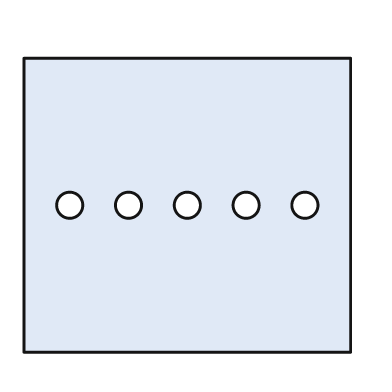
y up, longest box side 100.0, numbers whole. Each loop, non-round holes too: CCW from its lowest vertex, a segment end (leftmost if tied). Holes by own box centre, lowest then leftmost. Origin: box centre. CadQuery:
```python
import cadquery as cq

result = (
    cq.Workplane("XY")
    .moveTo(-50.0, -45.0)
    .lineTo(50.0, -45.0)
    .lineTo(50.0, 45.0)
    .lineTo(-50.0, 45.0)
    .close()
    .moveTo(-36.0, 0.0)
    .circle(4.0)
    .moveTo(-18.0, 0.0)
    .circle(4.0)
    .moveTo(0.0, 0.0)
    .circle(4.0)
    .moveTo(18.0, 0.0)
    .circle(4.0)
    .moveTo(36.0, 0.0)
    .circle(4.0)
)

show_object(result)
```